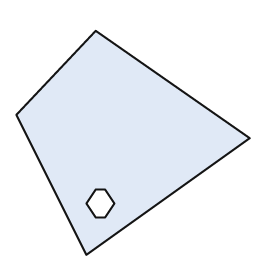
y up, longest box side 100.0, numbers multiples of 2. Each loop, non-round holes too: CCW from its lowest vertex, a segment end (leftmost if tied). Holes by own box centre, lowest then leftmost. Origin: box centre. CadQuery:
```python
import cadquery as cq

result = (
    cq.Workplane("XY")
    .moveTo(-20.0, -48.0)
    .lineTo(50.0, 2.0)
    .lineTo(-16.0, 48.0)
    .lineTo(-50.0, 12.0)
    .close()
    .moveTo(-16.0, -32.0)
    .lineTo(-12.0, -32.0)
    .lineTo(-8.0, -26.0)
    .lineTo(-12.0, -20.0)
    .lineTo(-16.0, -20.0)
    .lineTo(-20.0, -26.0)
    .close()
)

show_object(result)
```